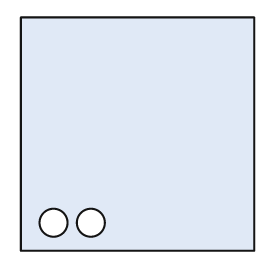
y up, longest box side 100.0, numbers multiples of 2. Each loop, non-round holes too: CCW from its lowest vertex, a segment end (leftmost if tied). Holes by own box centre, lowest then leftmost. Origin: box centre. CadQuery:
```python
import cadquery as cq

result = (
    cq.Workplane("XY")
    .moveTo(-50.0, -50.0)
    .lineTo(50.0, -50.0)
    .lineTo(50.0, 50.0)
    .lineTo(-50.0, 50.0)
    .close()
    .moveTo(-36.0, -38.0)
    .circle(6.0)
    .moveTo(-20.0, -38.0)
    .circle(6.0)
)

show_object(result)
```